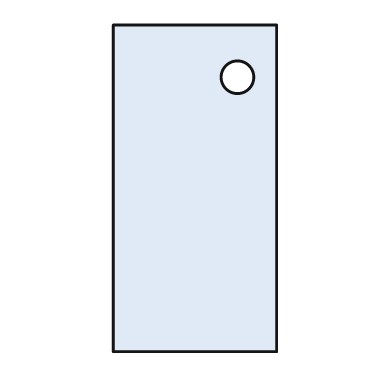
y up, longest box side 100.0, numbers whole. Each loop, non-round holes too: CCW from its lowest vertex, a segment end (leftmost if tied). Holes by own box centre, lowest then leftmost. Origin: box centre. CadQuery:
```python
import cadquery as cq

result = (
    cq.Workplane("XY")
    .moveTo(-25.0, -50.0)
    .lineTo(25.0, -50.0)
    .lineTo(25.0, 50.0)
    .lineTo(-25.0, 50.0)
    .close()
    .moveTo(13.0, 34.0)
    .circle(5.0)
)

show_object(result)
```